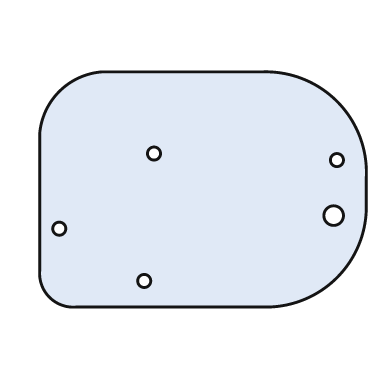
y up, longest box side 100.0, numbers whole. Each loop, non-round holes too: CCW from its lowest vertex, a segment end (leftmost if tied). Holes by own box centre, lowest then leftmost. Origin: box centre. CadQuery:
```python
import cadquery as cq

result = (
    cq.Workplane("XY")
    .moveTo(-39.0, -36.0)
    .lineTo(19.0, -36.0)
    .threePointArc((41.0, -27.0), (50.0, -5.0))
    .lineTo(50.0, 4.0)
    .threePointArc((41.0, 27.0), (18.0, 36.0))
    .lineTo(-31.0, 36.0)
    .threePointArc((-44.0, 30.0), (-50.0, 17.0))
    .lineTo(-50.0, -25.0)
    .threePointArc((-47.0, -33.0), (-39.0, -36.0))
    .close()
    .moveTo(-18.0, -28.0)
    .circle(2.0)
    .moveTo(-44.0, -12.0)
    .circle(2.0)
    .moveTo(40.0, -8.0)
    .circle(3.0)
    .moveTo(41.0, 9.0)
    .circle(2.0)
    .moveTo(-15.0, 11.0)
    .circle(2.0)
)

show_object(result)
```